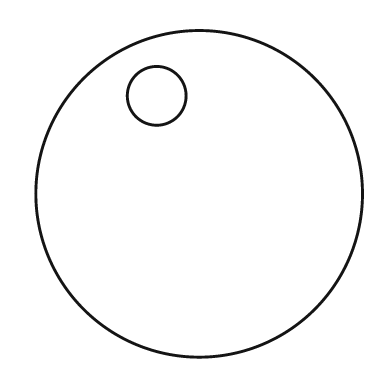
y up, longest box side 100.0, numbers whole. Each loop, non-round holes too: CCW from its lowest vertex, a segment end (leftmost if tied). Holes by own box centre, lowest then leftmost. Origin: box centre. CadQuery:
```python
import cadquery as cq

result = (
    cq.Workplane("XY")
    .moveTo(0.0, 0.0)
    .circle(50.0)
    .moveTo(-13.0, 30.0)
    .circle(9.0)
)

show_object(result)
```